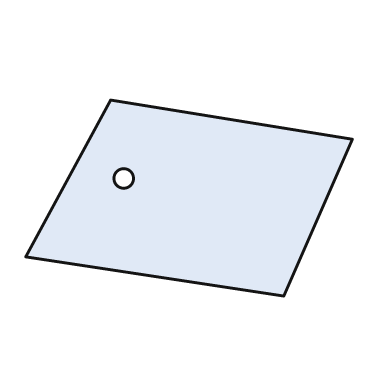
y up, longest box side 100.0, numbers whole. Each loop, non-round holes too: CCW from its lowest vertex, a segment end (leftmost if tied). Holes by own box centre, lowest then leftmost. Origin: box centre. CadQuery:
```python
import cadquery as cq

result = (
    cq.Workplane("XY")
    .moveTo(29.0, -30.0)
    .lineTo(50.0, 18.0)
    .lineTo(-24.0, 30.0)
    .lineTo(-50.0, -18.0)
    .close()
    .moveTo(-20.0, 6.0)
    .circle(3.0)
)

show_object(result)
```